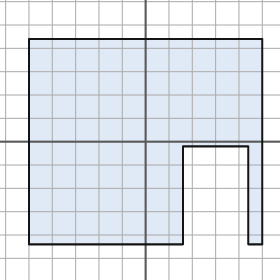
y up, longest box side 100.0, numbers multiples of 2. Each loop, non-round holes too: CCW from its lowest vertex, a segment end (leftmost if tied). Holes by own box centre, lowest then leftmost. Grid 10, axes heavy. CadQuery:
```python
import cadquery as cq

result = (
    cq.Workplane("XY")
    .moveTo(-50.0, -44.0)
    .lineTo(16.0, -44.0)
    .lineTo(16.0, -2.0)
    .lineTo(44.0, -2.0)
    .lineTo(44.0, -44.0)
    .lineTo(50.0, -44.0)
    .lineTo(50.0, 44.0)
    .lineTo(-50.0, 44.0)
    .close()
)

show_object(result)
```